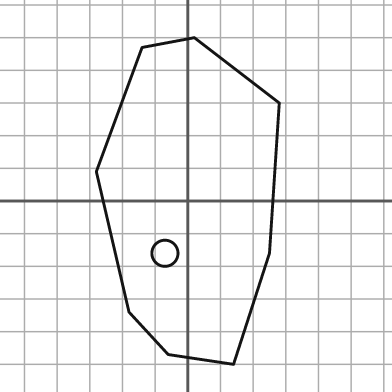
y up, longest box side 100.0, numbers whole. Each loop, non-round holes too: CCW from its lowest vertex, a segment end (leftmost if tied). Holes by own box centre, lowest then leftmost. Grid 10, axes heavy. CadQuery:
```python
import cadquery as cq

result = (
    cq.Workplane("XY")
    .moveTo(14.0, -50.0)
    .lineTo(25.0, -16.0)
    .lineTo(28.0, 30.0)
    .lineTo(2.0, 50.0)
    .lineTo(-14.0, 47.0)
    .lineTo(-28.0, 9.0)
    .lineTo(-18.0, -34.0)
    .lineTo(-6.0, -47.0)
    .close()
    .moveTo(-7.0, -16.0)
    .circle(4.0)
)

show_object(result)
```